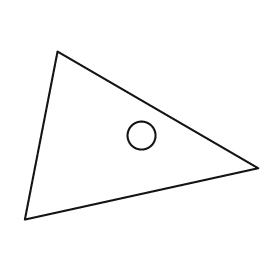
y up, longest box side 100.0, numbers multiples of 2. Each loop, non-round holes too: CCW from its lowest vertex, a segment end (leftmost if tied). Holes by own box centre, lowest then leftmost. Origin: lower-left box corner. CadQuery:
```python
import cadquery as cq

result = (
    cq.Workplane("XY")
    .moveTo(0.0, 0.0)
    .lineTo(100.0, 22.0)
    .lineTo(14.0, 72.0)
    .close()
    .moveTo(50.0, 36.0)
    .circle(6.0)
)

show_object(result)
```